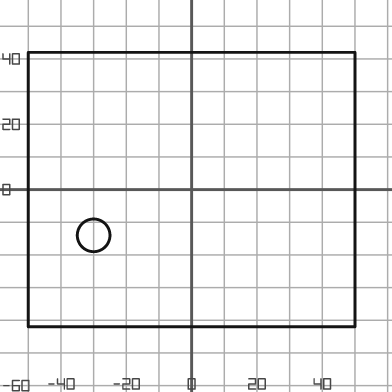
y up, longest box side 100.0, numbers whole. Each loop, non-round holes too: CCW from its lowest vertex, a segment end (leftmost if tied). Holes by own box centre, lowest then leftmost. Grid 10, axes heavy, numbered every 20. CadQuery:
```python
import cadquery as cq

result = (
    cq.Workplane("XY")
    .moveTo(-50.0, -42.0)
    .lineTo(50.0, -42.0)
    .lineTo(50.0, 42.0)
    .lineTo(-50.0, 42.0)
    .close()
    .moveTo(-30.0, -14.0)
    .circle(5.0)
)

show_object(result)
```